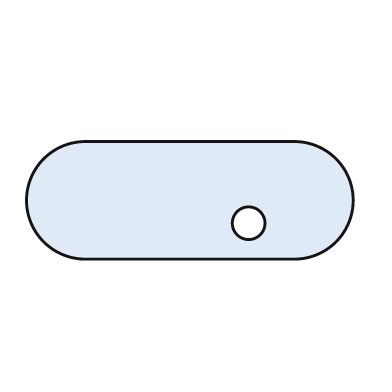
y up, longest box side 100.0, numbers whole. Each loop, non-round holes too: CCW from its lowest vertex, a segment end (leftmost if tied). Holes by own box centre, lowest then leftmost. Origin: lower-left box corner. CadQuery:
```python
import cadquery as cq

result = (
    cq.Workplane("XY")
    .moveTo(18.0, 0.0)
    .lineTo(82.0, 0.0)
    .threePointArc((100.0, 18.0), (82.0, 36.0))
    .lineTo(18.0, 36.0)
    .threePointArc((0.0, 18.0), (18.0, 0.0))
    .close()
    .moveTo(68.0, 11.0)
    .circle(5.0)
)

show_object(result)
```